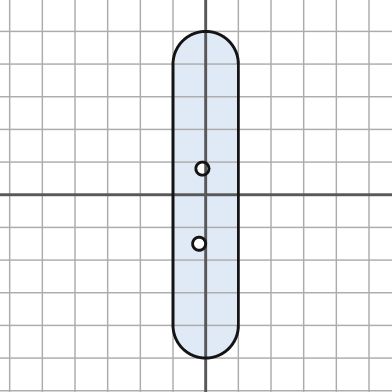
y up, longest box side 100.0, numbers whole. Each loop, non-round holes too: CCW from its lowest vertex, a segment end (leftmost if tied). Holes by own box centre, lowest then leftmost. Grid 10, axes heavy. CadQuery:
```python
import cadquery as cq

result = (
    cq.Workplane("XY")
    .moveTo(-10.0, -40.0)
    .threePointArc((0.0, -50.0), (10.0, -40.0))
    .lineTo(10.0, 40.0)
    .threePointArc((0.0, 50.0), (-10.0, 40.0))
    .close()
    .moveTo(-2.0, -15.0)
    .circle(2.0)
    .moveTo(-1.0, 8.0)
    .circle(2.0)
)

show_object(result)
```